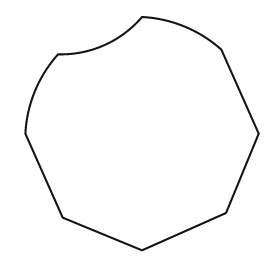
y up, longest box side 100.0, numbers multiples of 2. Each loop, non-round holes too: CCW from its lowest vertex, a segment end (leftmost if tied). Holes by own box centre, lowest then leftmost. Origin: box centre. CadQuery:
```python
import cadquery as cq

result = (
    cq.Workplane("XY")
    .moveTo(0.0, -50.0)
    .lineTo(36.0, -34.0)
    .lineTo(50.0, 0.0)
    .lineTo(34.0, 36.0)
    .threePointArc((18.0, 46.0), (0.0, 50.0))
    .threePointArc((-16.0, 38.0), (-36.0, 34.0))
    .threePointArc((-46.0, 18.0), (-50.0, 0.0))
    .lineTo(-34.0, -36.0)
    .close()
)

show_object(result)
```